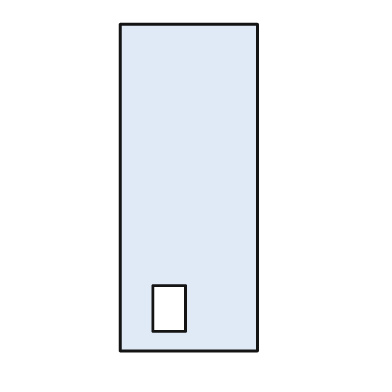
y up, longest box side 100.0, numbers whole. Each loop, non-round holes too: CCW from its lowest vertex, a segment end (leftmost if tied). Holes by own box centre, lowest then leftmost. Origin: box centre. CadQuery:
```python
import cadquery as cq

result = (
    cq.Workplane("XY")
    .moveTo(-21.0, -50.0)
    .lineTo(21.0, -50.0)
    .lineTo(21.0, 50.0)
    .lineTo(-21.0, 50.0)
    .close()
    .moveTo(-11.0, -44.0)
    .lineTo(-1.0, -44.0)
    .lineTo(-1.0, -30.0)
    .lineTo(-11.0, -30.0)
    .close()
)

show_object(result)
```